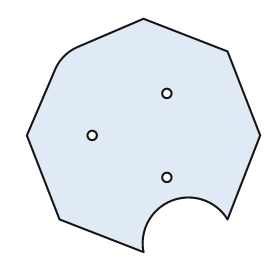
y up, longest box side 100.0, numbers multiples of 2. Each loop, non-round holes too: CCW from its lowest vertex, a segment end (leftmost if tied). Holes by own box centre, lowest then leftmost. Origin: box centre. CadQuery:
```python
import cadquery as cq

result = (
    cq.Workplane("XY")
    .moveTo(0.0, -50.0)
    .threePointArc((12.0, -28.0), (36.0, -36.0))
    .lineTo(50.0, 0.0)
    .lineTo(36.0, 36.0)
    .lineTo(0.0, 50.0)
    .lineTo(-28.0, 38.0)
    .threePointArc((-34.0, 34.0), (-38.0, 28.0))
    .lineTo(-50.0, 0.0)
    .lineTo(-36.0, -36.0)
    .close()
    .moveTo(10.0, -18.0)
    .circle(2.0)
    .moveTo(-22.0, 0.0)
    .circle(2.0)
    .moveTo(10.0, 18.0)
    .circle(2.0)
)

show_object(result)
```